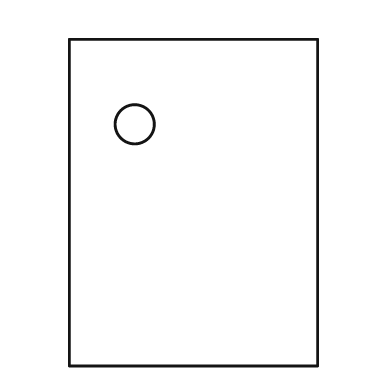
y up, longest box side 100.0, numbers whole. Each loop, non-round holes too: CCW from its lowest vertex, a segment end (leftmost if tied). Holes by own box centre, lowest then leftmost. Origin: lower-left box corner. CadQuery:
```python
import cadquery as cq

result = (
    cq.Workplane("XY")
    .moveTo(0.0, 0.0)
    .lineTo(76.0, 0.0)
    .lineTo(76.0, 100.0)
    .lineTo(0.0, 100.0)
    .close()
    .moveTo(20.0, 74.0)
    .circle(6.0)
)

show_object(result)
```